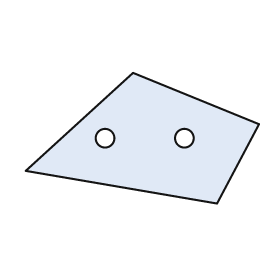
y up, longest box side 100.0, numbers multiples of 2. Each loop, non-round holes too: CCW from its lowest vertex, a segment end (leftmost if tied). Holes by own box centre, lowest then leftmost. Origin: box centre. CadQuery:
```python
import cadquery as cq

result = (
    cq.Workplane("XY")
    .moveTo(32.0, -28.0)
    .lineTo(50.0, 6.0)
    .lineTo(-4.0, 28.0)
    .lineTo(-50.0, -14.0)
    .close()
    .moveTo(-16.0, 0.0)
    .circle(4.0)
    .moveTo(18.0, 0.0)
    .circle(4.0)
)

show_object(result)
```